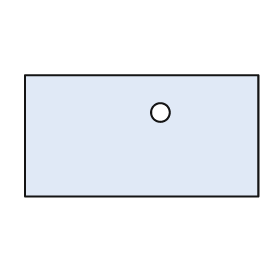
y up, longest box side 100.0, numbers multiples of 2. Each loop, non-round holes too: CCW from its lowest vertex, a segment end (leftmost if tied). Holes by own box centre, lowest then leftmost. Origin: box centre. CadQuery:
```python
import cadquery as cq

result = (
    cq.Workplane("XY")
    .moveTo(-50.0, -26.0)
    .lineTo(50.0, -26.0)
    .lineTo(50.0, 26.0)
    .lineTo(-50.0, 26.0)
    .close()
    .moveTo(8.0, 10.0)
    .circle(4.0)
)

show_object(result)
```